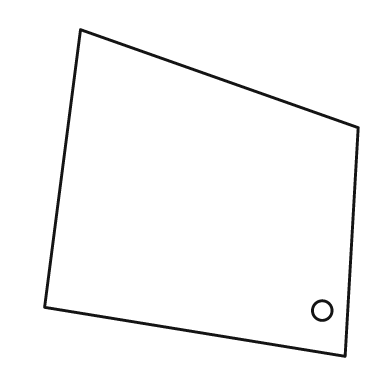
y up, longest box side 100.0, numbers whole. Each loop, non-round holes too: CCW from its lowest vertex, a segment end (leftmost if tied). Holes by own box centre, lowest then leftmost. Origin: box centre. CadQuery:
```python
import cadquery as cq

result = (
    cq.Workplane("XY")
    .moveTo(44.0, -50.0)
    .lineTo(48.0, 20.0)
    .lineTo(-37.0, 50.0)
    .lineTo(-48.0, -35.0)
    .close()
    .moveTo(37.0, -36.0)
    .circle(3.0)
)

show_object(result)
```